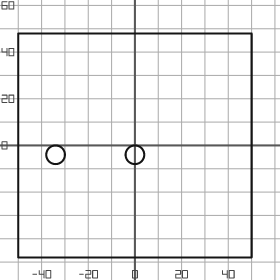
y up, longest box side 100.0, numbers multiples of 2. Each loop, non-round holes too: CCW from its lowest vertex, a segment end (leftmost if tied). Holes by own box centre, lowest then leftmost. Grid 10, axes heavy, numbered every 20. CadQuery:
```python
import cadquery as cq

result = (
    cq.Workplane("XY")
    .moveTo(-50.0, -48.0)
    .lineTo(50.0, -48.0)
    .lineTo(50.0, 48.0)
    .lineTo(-50.0, 48.0)
    .close()
    .moveTo(-34.0, -4.0)
    .circle(4.0)
    .moveTo(0.0, -4.0)
    .circle(4.0)
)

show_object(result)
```